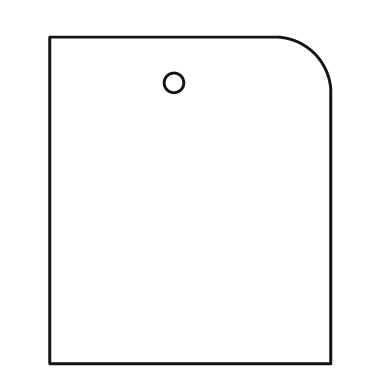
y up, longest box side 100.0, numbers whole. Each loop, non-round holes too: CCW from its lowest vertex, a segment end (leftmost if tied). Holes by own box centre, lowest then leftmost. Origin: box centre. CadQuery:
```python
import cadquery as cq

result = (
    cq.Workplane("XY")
    .moveTo(-43.0, -50.0)
    .lineTo(43.0, -50.0)
    .lineTo(43.0, 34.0)
    .threePointArc((38.0, 45.0), (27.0, 50.0))
    .lineTo(-43.0, 50.0)
    .close()
    .moveTo(-5.0, 36.0)
    .circle(3.0)
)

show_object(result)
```